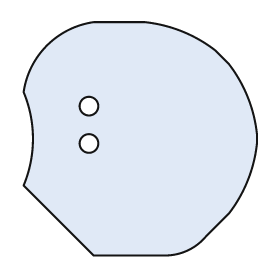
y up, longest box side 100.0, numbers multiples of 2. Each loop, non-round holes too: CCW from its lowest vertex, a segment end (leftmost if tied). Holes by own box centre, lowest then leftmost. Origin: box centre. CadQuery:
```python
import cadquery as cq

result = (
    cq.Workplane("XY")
    .moveTo(-20.0, -50.0)
    .lineTo(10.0, -50.0)
    .threePointArc((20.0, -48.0), (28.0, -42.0))
    .lineTo(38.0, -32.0)
    .threePointArc((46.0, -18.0), (50.0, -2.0))
    .lineTo(50.0, 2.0)
    .threePointArc((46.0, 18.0), (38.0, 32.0))
    .lineTo(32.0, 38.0)
    .threePointArc((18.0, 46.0), (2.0, 50.0))
    .lineTo(-20.0, 50.0)
    .threePointArc((-40.0, 40.0), (-50.0, 20.0))
    .threePointArc((-46.0, 0.0), (-50.0, -20.0))
    .close()
    .moveTo(-22.0, -2.0)
    .circle(4.0)
    .moveTo(-22.0, 14.0)
    .circle(4.0)
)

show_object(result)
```